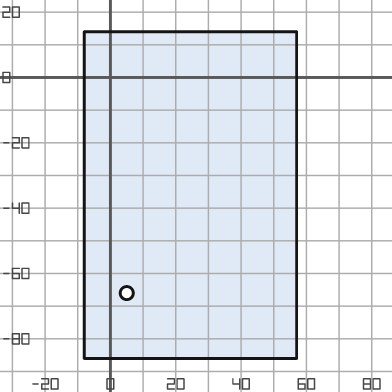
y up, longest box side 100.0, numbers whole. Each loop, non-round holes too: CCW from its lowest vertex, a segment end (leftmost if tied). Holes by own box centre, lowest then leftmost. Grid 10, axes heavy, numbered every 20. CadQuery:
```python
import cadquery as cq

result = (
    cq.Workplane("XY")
    .moveTo(-8.0, -86.0)
    .lineTo(57.0, -86.0)
    .lineTo(57.0, 14.0)
    .lineTo(-8.0, 14.0)
    .close()
    .moveTo(5.0, -66.0)
    .circle(2.0)
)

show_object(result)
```